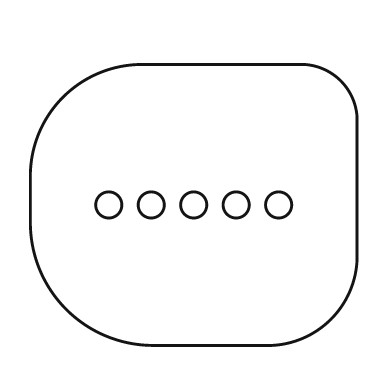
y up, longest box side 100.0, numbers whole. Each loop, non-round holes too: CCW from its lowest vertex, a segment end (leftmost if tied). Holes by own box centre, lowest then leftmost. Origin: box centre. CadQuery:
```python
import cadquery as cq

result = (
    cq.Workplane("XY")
    .moveTo(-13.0, -43.0)
    .lineTo(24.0, -43.0)
    .threePointArc((42.0, -35.0), (50.0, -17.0))
    .lineTo(50.0, 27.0)
    .threePointArc((45.0, 38.0), (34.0, 43.0))
    .lineTo(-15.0, 43.0)
    .threePointArc((-40.0, 33.0), (-50.0, 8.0))
    .lineTo(-50.0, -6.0)
    .threePointArc((-39.0, -32.0), (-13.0, -43.0))
    .close()
    .moveTo(-26.0, 0.0)
    .circle(4.0)
    .moveTo(-13.0, 0.0)
    .circle(4.0)
    .moveTo(0.0, 0.0)
    .circle(4.0)
    .moveTo(13.0, 0.0)
    .circle(4.0)
    .moveTo(26.0, 0.0)
    .circle(4.0)
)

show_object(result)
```